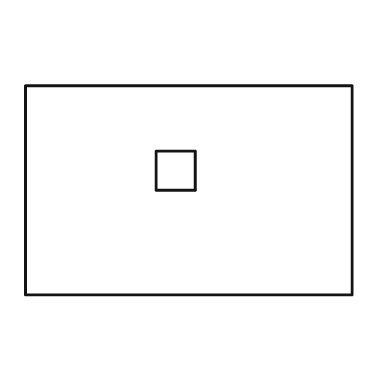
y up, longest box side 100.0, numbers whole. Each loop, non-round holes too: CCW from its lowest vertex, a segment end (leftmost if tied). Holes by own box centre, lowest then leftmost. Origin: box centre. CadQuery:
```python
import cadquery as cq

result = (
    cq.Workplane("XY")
    .moveTo(-50.0, -32.0)
    .lineTo(50.0, -32.0)
    .lineTo(50.0, 32.0)
    .lineTo(-50.0, 32.0)
    .close()
    .moveTo(-10.0, 0.0)
    .lineTo(2.0, 0.0)
    .lineTo(2.0, 12.0)
    .lineTo(-10.0, 12.0)
    .close()
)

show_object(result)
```